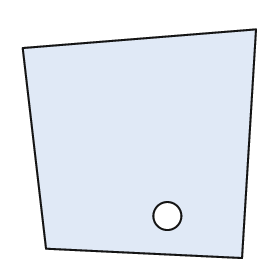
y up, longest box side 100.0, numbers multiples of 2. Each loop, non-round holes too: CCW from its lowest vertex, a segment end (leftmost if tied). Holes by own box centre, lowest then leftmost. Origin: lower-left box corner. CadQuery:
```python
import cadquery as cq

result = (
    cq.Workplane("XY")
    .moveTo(94.0, 0.0)
    .lineTo(100.0, 98.0)
    .lineTo(0.0, 90.0)
    .lineTo(10.0, 4.0)
    .close()
    .moveTo(62.0, 18.0)
    .circle(6.0)
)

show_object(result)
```